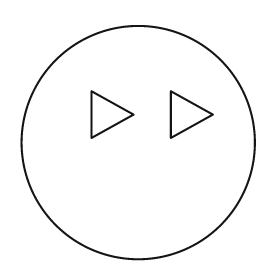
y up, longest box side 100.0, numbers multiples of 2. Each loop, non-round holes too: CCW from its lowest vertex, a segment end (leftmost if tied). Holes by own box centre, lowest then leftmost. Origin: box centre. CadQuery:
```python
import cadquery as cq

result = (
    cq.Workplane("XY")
    .moveTo(0.0, 0.0)
    .circle(50.0)
    .moveTo(-20.0, 2.0)
    .lineTo(-2.0, 12.0)
    .lineTo(-20.0, 22.0)
    .close()
    .moveTo(14.0, 2.0)
    .lineTo(32.0, 12.0)
    .lineTo(14.0, 22.0)
    .close()
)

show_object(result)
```